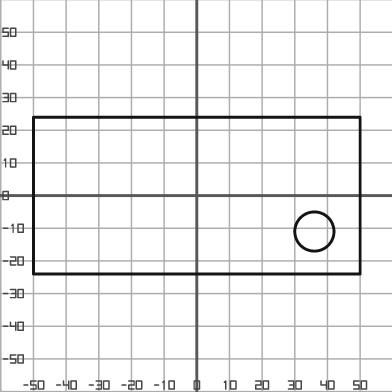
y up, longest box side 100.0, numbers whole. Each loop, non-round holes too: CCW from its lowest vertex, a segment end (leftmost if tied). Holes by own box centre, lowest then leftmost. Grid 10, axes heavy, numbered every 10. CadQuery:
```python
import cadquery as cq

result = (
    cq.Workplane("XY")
    .moveTo(-50.0, -24.0)
    .lineTo(50.0, -24.0)
    .lineTo(50.0, 24.0)
    .lineTo(-50.0, 24.0)
    .close()
    .moveTo(36.0, -11.0)
    .circle(6.0)
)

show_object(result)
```